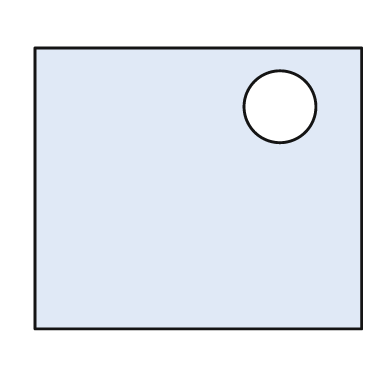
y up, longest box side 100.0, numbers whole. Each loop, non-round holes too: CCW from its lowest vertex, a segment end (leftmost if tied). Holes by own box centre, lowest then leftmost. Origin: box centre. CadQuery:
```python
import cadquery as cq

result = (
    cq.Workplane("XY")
    .moveTo(-50.0, -43.0)
    .lineTo(50.0, -43.0)
    .lineTo(50.0, 43.0)
    .lineTo(-50.0, 43.0)
    .close()
    .moveTo(25.0, 25.0)
    .circle(11.0)
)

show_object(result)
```